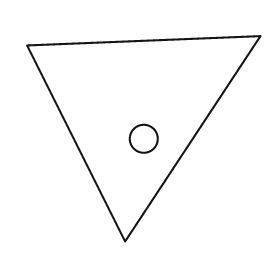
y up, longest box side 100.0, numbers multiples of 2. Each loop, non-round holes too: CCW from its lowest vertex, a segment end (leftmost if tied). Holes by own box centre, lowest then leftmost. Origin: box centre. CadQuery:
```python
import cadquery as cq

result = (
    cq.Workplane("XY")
    .moveTo(-8.0, -44.0)
    .lineTo(50.0, 44.0)
    .lineTo(-50.0, 40.0)
    .close()
    .moveTo(0.0, 0.0)
    .circle(6.0)
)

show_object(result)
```